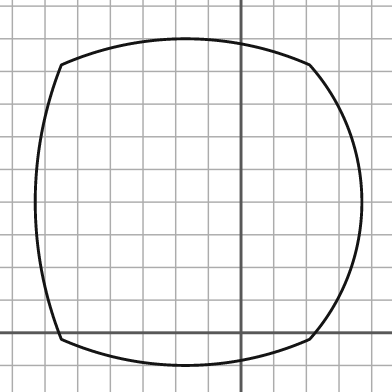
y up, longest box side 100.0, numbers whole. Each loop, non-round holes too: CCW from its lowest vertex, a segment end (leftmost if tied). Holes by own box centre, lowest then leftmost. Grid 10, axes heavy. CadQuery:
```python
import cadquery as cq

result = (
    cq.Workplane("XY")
    .moveTo(-55.0, -2.0)
    .threePointArc((-17.0, -10.0), (21.0, -2.0))
    .threePointArc((37.0, 40.0), (21.0, 82.0))
    .threePointArc((-17.0, 90.0), (-55.0, 82.0))
    .threePointArc((-63.0, 40.0), (-55.0, -2.0))
    .close()
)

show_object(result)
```